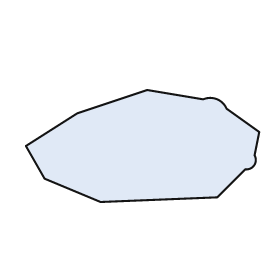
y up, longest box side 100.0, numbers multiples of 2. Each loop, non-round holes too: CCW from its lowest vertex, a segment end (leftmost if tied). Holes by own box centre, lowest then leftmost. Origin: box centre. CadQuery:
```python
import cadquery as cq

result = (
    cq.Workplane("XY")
    .moveTo(-18.0, -24.0)
    .lineTo(32.0, -22.0)
    .lineTo(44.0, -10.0)
    .threePointArc((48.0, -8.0), (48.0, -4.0))
    .lineTo(50.0, 6.0)
    .lineTo(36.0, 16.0)
    .threePointArc((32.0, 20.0), (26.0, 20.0))
    .lineTo(2.0, 24.0)
    .lineTo(-28.0, 14.0)
    .lineTo(-50.0, 0.0)
    .lineTo(-42.0, -14.0)
    .close()
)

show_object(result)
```